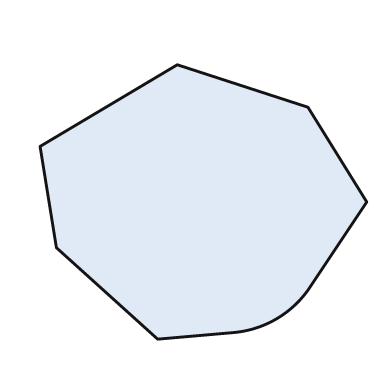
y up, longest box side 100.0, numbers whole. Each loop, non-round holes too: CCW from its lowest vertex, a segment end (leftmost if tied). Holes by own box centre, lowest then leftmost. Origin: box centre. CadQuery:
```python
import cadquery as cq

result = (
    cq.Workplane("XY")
    .moveTo(-14.0, -42.0)
    .lineTo(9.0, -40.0)
    .threePointArc((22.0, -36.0), (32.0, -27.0))
    .lineTo(50.0, 0.0)
    .lineTo(32.0, 29.0)
    .lineTo(-8.0, 42.0)
    .lineTo(-50.0, 17.0)
    .lineTo(-45.0, -14.0)
    .close()
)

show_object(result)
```